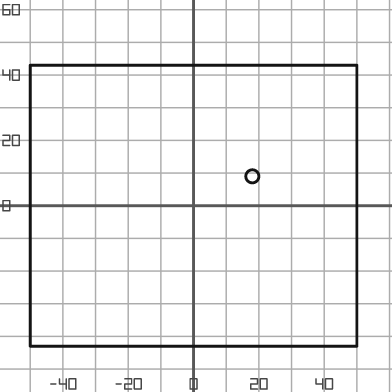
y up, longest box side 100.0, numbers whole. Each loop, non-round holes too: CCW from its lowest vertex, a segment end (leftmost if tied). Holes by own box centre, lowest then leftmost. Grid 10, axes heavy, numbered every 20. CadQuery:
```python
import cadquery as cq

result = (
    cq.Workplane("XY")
    .moveTo(-50.0, -43.0)
    .lineTo(50.0, -43.0)
    .lineTo(50.0, 43.0)
    .lineTo(-50.0, 43.0)
    .close()
    .moveTo(18.0, 9.0)
    .circle(2.0)
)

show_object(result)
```